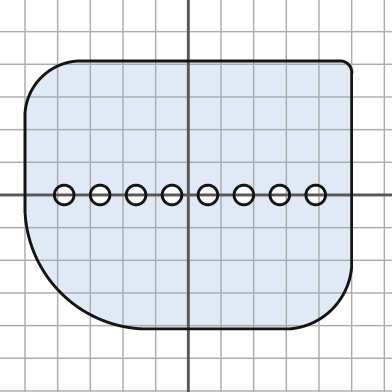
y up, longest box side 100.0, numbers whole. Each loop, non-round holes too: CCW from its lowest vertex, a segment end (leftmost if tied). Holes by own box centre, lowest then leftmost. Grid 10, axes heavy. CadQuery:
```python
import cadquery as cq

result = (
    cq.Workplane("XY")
    .moveTo(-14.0, -41.0)
    .lineTo(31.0, -41.0)
    .threePointArc((44.0, -35.0), (50.0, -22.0))
    .lineTo(50.0, 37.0)
    .threePointArc((49.0, 40.0), (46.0, 41.0))
    .lineTo(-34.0, 41.0)
    .threePointArc((-45.0, 36.0), (-50.0, 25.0))
    .lineTo(-50.0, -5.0)
    .threePointArc((-39.0, -30.0), (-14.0, -41.0))
    .close()
    .moveTo(-38.0, 0.0)
    .circle(3.0)
    .moveTo(-27.0, 0.0)
    .circle(3.0)
    .moveTo(-16.0, 0.0)
    .circle(3.0)
    .moveTo(-5.0, 0.0)
    .circle(3.0)
    .moveTo(6.0, 0.0)
    .circle(3.0)
    .moveTo(17.0, 0.0)
    .circle(3.0)
    .moveTo(28.0, 0.0)
    .circle(3.0)
    .moveTo(39.0, 0.0)
    .circle(3.0)
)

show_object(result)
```